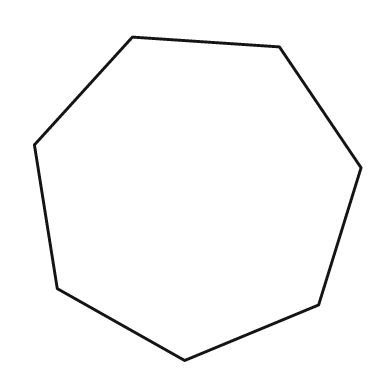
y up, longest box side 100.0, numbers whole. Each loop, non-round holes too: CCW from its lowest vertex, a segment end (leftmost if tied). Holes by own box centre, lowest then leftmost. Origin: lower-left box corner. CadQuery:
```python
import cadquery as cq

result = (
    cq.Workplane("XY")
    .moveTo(46.0, 0.0)
    .lineTo(87.0, 17.0)
    .lineTo(100.0, 59.0)
    .lineTo(75.0, 96.0)
    .lineTo(30.0, 99.0)
    .lineTo(0.0, 66.0)
    .lineTo(7.0, 22.0)
    .close()
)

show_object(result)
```